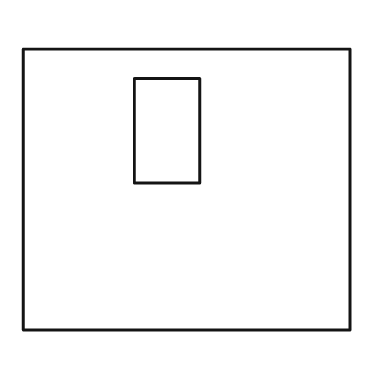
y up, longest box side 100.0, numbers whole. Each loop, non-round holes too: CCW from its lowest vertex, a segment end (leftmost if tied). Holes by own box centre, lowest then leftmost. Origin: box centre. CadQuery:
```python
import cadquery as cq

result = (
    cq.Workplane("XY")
    .moveTo(-50.0, -43.0)
    .lineTo(50.0, -43.0)
    .lineTo(50.0, 43.0)
    .lineTo(-50.0, 43.0)
    .close()
    .moveTo(-16.0, 2.0)
    .lineTo(4.0, 2.0)
    .lineTo(4.0, 34.0)
    .lineTo(-16.0, 34.0)
    .close()
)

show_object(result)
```